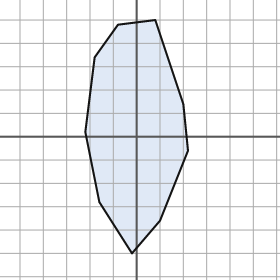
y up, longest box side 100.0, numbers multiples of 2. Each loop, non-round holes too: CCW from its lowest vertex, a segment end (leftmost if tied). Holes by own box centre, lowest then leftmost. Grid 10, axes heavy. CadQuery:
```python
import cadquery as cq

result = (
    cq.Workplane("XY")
    .moveTo(-2.0, -50.0)
    .lineTo(10.0, -36.0)
    .lineTo(22.0, -6.0)
    .lineTo(20.0, 14.0)
    .lineTo(8.0, 50.0)
    .lineTo(-8.0, 48.0)
    .lineTo(-18.0, 34.0)
    .lineTo(-22.0, 2.0)
    .lineTo(-16.0, -28.0)
    .close()
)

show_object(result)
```